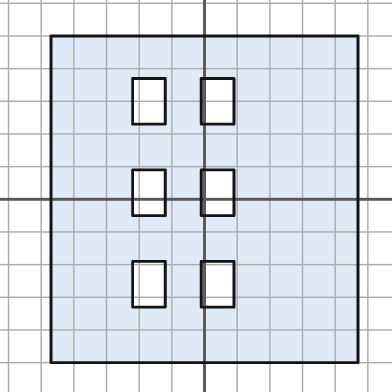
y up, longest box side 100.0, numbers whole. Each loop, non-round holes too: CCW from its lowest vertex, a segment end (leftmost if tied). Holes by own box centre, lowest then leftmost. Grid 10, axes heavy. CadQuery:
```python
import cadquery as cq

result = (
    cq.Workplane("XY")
    .moveTo(-47.0, -50.0)
    .lineTo(47.0, -50.0)
    .lineTo(47.0, 50.0)
    .lineTo(-47.0, 50.0)
    .close()
    .moveTo(-22.0, -33.0)
    .lineTo(-12.0, -33.0)
    .lineTo(-12.0, -19.0)
    .lineTo(-22.0, -19.0)
    .close()
    .moveTo(-1.0, -33.0)
    .lineTo(9.0, -33.0)
    .lineTo(9.0, -19.0)
    .lineTo(-1.0, -19.0)
    .close()
    .moveTo(-22.0, -5.0)
    .lineTo(-12.0, -5.0)
    .lineTo(-12.0, 9.0)
    .lineTo(-22.0, 9.0)
    .close()
    .moveTo(-1.0, -5.0)
    .lineTo(9.0, -5.0)
    .lineTo(9.0, 9.0)
    .lineTo(-1.0, 9.0)
    .close()
    .moveTo(-22.0, 23.0)
    .lineTo(-12.0, 23.0)
    .lineTo(-12.0, 37.0)
    .lineTo(-22.0, 37.0)
    .close()
    .moveTo(-1.0, 23.0)
    .lineTo(9.0, 23.0)
    .lineTo(9.0, 37.0)
    .lineTo(-1.0, 37.0)
    .close()
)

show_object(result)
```